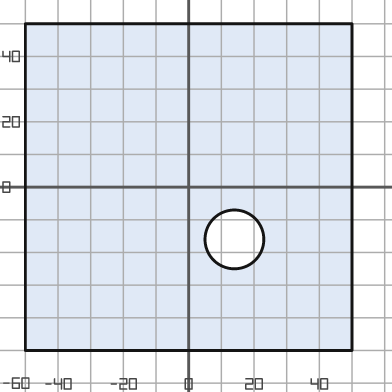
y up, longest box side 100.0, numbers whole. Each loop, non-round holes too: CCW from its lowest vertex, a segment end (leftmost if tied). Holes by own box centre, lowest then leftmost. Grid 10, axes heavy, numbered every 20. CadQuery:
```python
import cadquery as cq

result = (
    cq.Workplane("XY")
    .moveTo(-50.0, -50.0)
    .lineTo(50.0, -50.0)
    .lineTo(50.0, 50.0)
    .lineTo(-50.0, 50.0)
    .close()
    .moveTo(14.0, -16.0)
    .circle(9.0)
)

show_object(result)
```